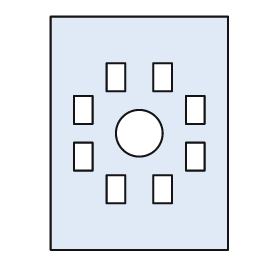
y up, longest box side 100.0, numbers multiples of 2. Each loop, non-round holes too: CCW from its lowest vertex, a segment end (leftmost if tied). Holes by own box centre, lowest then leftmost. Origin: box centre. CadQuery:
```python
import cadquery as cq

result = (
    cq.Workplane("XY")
    .moveTo(-38.0, -50.0)
    .lineTo(38.0, -50.0)
    .lineTo(38.0, 50.0)
    .lineTo(-38.0, 50.0)
    .close()
    .moveTo(-14.0, -30.0)
    .lineTo(-6.0, -30.0)
    .lineTo(-6.0, -18.0)
    .lineTo(-14.0, -18.0)
    .close()
    .moveTo(6.0, -30.0)
    .lineTo(14.0, -30.0)
    .lineTo(14.0, -18.0)
    .lineTo(6.0, -18.0)
    .close()
    .moveTo(-28.0, -16.0)
    .lineTo(-20.0, -16.0)
    .lineTo(-20.0, -4.0)
    .lineTo(-28.0, -4.0)
    .close()
    .moveTo(20.0, -16.0)
    .lineTo(28.0, -16.0)
    .lineTo(28.0, -4.0)
    .lineTo(20.0, -4.0)
    .close()
    .moveTo(0.0, 0.0)
    .circle(10.0)
    .moveTo(-28.0, 4.0)
    .lineTo(-20.0, 4.0)
    .lineTo(-20.0, 16.0)
    .lineTo(-28.0, 16.0)
    .close()
    .moveTo(20.0, 4.0)
    .lineTo(28.0, 4.0)
    .lineTo(28.0, 16.0)
    .lineTo(20.0, 16.0)
    .close()
    .moveTo(-14.0, 18.0)
    .lineTo(-6.0, 18.0)
    .lineTo(-6.0, 30.0)
    .lineTo(-14.0, 30.0)
    .close()
    .moveTo(6.0, 18.0)
    .lineTo(14.0, 18.0)
    .lineTo(14.0, 30.0)
    .lineTo(6.0, 30.0)
    .close()
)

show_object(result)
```